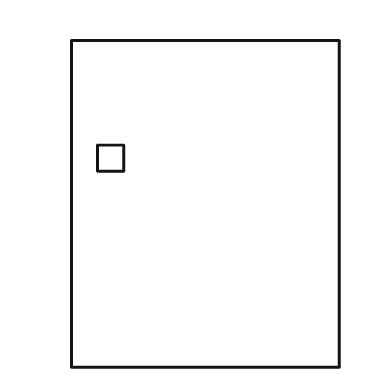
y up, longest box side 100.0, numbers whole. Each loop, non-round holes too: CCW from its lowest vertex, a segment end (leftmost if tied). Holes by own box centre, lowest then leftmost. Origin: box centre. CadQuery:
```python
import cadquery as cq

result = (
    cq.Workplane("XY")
    .moveTo(-41.0, -50.0)
    .lineTo(41.0, -50.0)
    .lineTo(41.0, 50.0)
    .lineTo(-41.0, 50.0)
    .close()
    .moveTo(-33.0, 10.0)
    .lineTo(-25.0, 10.0)
    .lineTo(-25.0, 18.0)
    .lineTo(-33.0, 18.0)
    .close()
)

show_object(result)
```